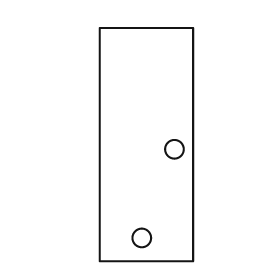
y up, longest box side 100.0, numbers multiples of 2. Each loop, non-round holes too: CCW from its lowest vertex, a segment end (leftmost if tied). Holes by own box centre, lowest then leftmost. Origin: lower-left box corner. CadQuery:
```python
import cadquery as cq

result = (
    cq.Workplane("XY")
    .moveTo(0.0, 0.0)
    .lineTo(40.0, 0.0)
    .lineTo(40.0, 100.0)
    .lineTo(0.0, 100.0)
    .close()
    .moveTo(18.0, 10.0)
    .circle(4.0)
    .moveTo(32.0, 48.0)
    .circle(4.0)
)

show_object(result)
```